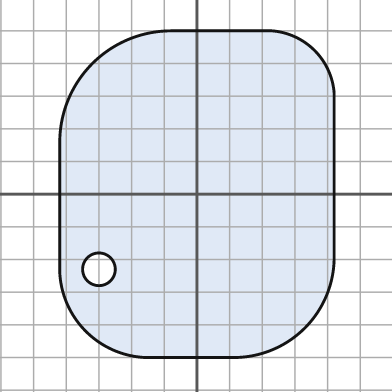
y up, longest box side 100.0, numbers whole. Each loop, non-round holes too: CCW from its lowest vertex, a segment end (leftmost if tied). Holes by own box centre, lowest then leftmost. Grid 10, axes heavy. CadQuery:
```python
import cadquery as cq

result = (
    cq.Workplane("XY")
    .moveTo(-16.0, -50.0)
    .lineTo(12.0, -50.0)
    .threePointArc((33.0, -41.0), (42.0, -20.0))
    .lineTo(42.0, 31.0)
    .threePointArc((36.0, 44.0), (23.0, 50.0))
    .lineTo(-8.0, 50.0)
    .threePointArc((-32.0, 40.0), (-42.0, 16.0))
    .lineTo(-42.0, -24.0)
    .threePointArc((-34.0, -42.0), (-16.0, -50.0))
    .close()
    .moveTo(-30.0, -23.0)
    .circle(5.0)
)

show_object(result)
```